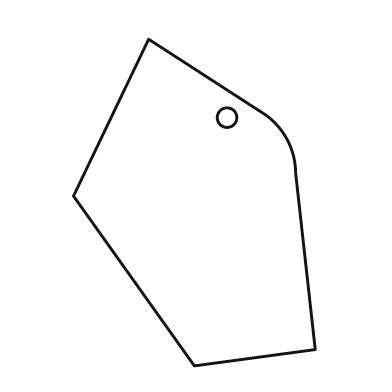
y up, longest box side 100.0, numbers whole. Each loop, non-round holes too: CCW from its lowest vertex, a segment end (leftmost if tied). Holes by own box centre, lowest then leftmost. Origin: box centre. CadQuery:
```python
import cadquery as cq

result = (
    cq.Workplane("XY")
    .moveTo(0.0, -50.0)
    .lineTo(37.0, -45.0)
    .lineTo(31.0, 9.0)
    .threePointArc((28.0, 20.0), (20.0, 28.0))
    .lineTo(-14.0, 50.0)
    .lineTo(-37.0, 2.0)
    .close()
    .moveTo(10.0, 26.0)
    .circle(3.0)
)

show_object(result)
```